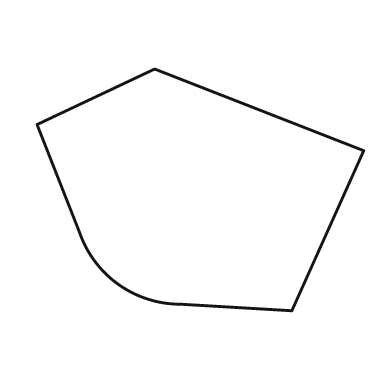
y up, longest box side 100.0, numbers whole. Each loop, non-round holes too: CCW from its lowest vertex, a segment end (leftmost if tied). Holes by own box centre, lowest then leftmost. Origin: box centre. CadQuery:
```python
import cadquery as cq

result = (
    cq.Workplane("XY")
    .moveTo(28.0, -37.0)
    .lineTo(50.0, 12.0)
    .lineTo(-14.0, 37.0)
    .lineTo(-50.0, 20.0)
    .lineTo(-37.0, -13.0)
    .threePointArc((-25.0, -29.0), (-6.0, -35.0))
    .close()
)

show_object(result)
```